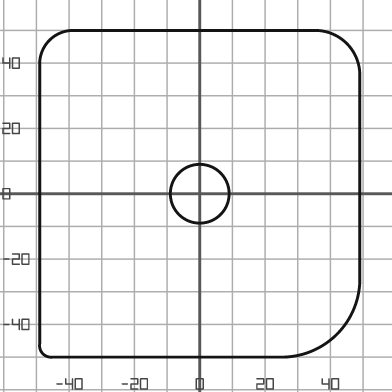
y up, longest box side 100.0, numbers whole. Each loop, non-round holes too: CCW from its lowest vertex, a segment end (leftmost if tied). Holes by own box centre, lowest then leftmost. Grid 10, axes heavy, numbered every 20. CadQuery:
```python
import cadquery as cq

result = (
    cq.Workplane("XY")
    .moveTo(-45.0, -50.0)
    .lineTo(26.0, -50.0)
    .threePointArc((42.0, -43.0), (49.0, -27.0))
    .lineTo(49.0, 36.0)
    .threePointArc((45.0, 46.0), (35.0, 50.0))
    .lineTo(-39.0, 50.0)
    .threePointArc((-46.0, 47.0), (-49.0, 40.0))
    .lineTo(-49.0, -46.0)
    .threePointArc((-48.0, -49.0), (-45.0, -50.0))
    .close()
    .moveTo(0.0, 0.0)
    .circle(9.0)
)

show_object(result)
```